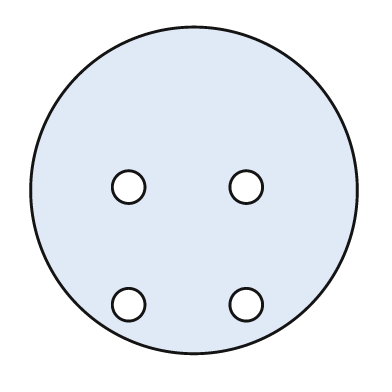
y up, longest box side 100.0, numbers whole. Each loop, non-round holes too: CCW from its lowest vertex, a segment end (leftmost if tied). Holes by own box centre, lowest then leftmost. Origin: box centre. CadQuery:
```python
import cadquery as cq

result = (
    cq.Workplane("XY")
    .moveTo(0.0, 0.0)
    .circle(50.0)
    .moveTo(-20.0, -35.0)
    .circle(5.0)
    .moveTo(16.0, -35.0)
    .circle(5.0)
    .moveTo(-20.0, 1.0)
    .circle(5.0)
    .moveTo(16.0, 1.0)
    .circle(5.0)
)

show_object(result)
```